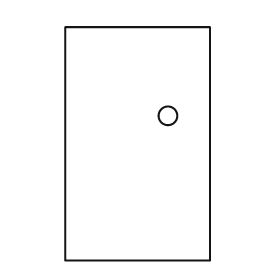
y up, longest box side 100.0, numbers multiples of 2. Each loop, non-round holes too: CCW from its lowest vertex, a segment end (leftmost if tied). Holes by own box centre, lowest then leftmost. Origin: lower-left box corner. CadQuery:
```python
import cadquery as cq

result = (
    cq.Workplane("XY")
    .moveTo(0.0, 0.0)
    .lineTo(62.0, 0.0)
    .lineTo(62.0, 100.0)
    .lineTo(0.0, 100.0)
    .close()
    .moveTo(44.0, 62.0)
    .circle(4.0)
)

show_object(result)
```